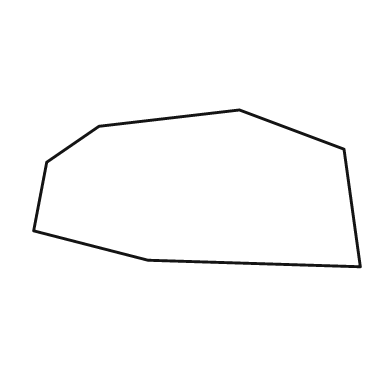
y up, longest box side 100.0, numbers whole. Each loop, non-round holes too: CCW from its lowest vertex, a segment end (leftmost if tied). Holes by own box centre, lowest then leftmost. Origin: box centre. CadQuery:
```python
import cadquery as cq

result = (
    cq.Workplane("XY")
    .moveTo(50.0, -24.0)
    .lineTo(45.0, 12.0)
    .lineTo(13.0, 24.0)
    .lineTo(-30.0, 19.0)
    .lineTo(-46.0, 8.0)
    .lineTo(-50.0, -13.0)
    .lineTo(-15.0, -22.0)
    .close()
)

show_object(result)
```